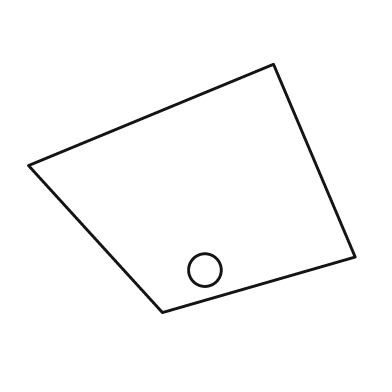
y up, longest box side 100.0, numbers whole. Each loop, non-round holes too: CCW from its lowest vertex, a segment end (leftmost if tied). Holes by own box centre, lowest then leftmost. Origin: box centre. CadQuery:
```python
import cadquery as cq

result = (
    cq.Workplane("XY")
    .moveTo(-9.0, -38.0)
    .lineTo(50.0, -21.0)
    .lineTo(25.0, 38.0)
    .lineTo(-50.0, 7.0)
    .close()
    .moveTo(4.0, -25.0)
    .circle(5.0)
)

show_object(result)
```